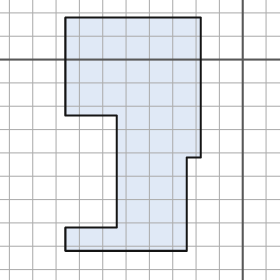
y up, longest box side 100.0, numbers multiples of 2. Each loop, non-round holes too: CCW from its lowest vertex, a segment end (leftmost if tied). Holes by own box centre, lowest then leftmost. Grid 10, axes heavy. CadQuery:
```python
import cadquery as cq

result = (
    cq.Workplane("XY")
    .moveTo(-76.0, -82.0)
    .lineTo(-24.0, -82.0)
    .lineTo(-24.0, -42.0)
    .lineTo(-18.0, -42.0)
    .lineTo(-18.0, 18.0)
    .lineTo(-76.0, 18.0)
    .lineTo(-76.0, -24.0)
    .lineTo(-54.0, -24.0)
    .lineTo(-54.0, -72.0)
    .lineTo(-76.0, -72.0)
    .close()
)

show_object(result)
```